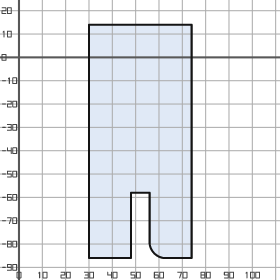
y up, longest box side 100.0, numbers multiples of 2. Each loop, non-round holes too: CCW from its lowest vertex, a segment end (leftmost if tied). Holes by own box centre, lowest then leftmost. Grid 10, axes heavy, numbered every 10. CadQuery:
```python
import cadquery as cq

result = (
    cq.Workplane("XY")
    .moveTo(30.0, -86.0)
    .lineTo(48.0, -86.0)
    .lineTo(48.0, -58.0)
    .lineTo(56.0, -58.0)
    .lineTo(56.0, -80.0)
    .threePointArc((58.0, -84.0), (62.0, -86.0))
    .lineTo(74.0, -86.0)
    .lineTo(74.0, 14.0)
    .lineTo(30.0, 14.0)
    .close()
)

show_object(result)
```